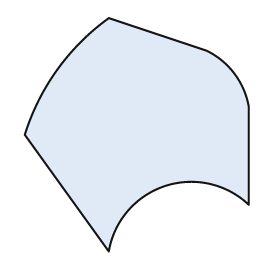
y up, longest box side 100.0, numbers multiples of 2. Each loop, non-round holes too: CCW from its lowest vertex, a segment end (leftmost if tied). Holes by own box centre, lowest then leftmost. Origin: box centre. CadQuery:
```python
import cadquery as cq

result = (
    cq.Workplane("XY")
    .moveTo(-12.0, -50.0)
    .threePointArc((12.0, -22.0), (48.0, -30.0))
    .lineTo(48.0, 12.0)
    .threePointArc((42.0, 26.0), (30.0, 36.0))
    .lineTo(-12.0, 50.0)
    .threePointArc((-34.0, 28.0), (-48.0, 0.0))
    .close()
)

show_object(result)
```